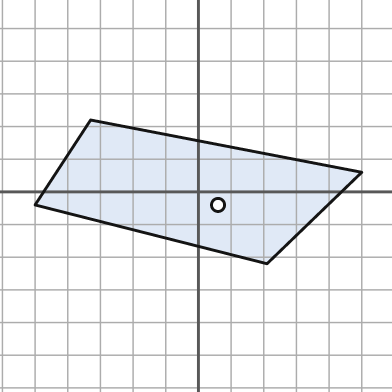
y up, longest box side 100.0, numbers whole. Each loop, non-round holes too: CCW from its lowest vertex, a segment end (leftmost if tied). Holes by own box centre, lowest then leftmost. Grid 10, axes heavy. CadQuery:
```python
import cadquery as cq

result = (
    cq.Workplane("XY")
    .moveTo(21.0, -22.0)
    .lineTo(50.0, 6.0)
    .lineTo(-33.0, 22.0)
    .lineTo(-50.0, -4.0)
    .close()
    .moveTo(6.0, -4.0)
    .circle(2.0)
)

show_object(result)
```